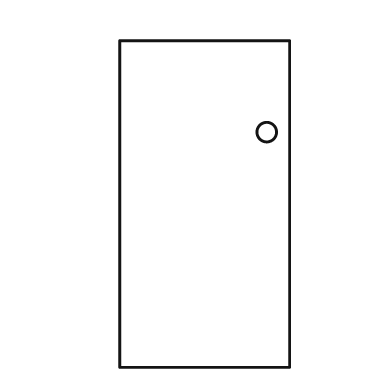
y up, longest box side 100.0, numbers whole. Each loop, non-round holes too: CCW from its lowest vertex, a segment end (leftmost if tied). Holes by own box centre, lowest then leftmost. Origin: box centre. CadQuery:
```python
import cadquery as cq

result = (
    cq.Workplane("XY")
    .moveTo(-26.0, -50.0)
    .lineTo(26.0, -50.0)
    .lineTo(26.0, 50.0)
    .lineTo(-26.0, 50.0)
    .close()
    .moveTo(19.0, 22.0)
    .circle(3.0)
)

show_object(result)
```